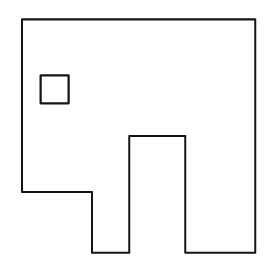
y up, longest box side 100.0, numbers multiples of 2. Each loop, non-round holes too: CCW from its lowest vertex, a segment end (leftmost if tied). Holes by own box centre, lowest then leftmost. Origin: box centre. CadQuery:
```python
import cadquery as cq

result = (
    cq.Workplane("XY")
    .moveTo(-20.0, -50.0)
    .lineTo(-4.0, -50.0)
    .lineTo(-4.0, 0.0)
    .lineTo(20.0, 0.0)
    .lineTo(20.0, -50.0)
    .lineTo(50.0, -50.0)
    .lineTo(50.0, 50.0)
    .lineTo(-50.0, 50.0)
    .lineTo(-50.0, -24.0)
    .lineTo(-20.0, -24.0)
    .close()
    .moveTo(-42.0, 14.0)
    .lineTo(-30.0, 14.0)
    .lineTo(-30.0, 26.0)
    .lineTo(-42.0, 26.0)
    .close()
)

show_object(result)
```